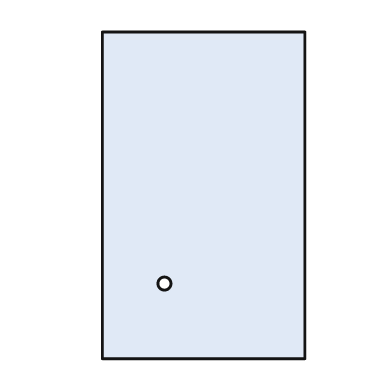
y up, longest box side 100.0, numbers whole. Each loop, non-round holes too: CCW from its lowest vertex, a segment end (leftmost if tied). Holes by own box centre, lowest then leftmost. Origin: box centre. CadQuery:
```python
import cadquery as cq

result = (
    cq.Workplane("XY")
    .moveTo(-31.0, -50.0)
    .lineTo(31.0, -50.0)
    .lineTo(31.0, 50.0)
    .lineTo(-31.0, 50.0)
    .close()
    .moveTo(-12.0, -27.0)
    .circle(2.0)
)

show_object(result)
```